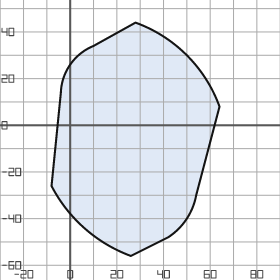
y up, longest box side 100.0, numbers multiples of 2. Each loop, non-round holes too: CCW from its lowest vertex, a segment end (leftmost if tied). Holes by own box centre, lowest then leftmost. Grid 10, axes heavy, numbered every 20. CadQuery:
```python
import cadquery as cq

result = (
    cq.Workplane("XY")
    .moveTo(26.0, -56.0)
    .lineTo(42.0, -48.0)
    .threePointArc((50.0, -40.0), (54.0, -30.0))
    .lineTo(64.0, 8.0)
    .threePointArc((50.0, 30.0), (28.0, 44.0))
    .lineTo(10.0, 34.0)
    .threePointArc((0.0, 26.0), (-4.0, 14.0))
    .lineTo(-8.0, -26.0)
    .threePointArc((6.0, -44.0), (26.0, -56.0))
    .close()
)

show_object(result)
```